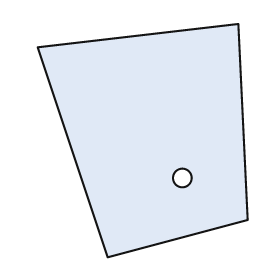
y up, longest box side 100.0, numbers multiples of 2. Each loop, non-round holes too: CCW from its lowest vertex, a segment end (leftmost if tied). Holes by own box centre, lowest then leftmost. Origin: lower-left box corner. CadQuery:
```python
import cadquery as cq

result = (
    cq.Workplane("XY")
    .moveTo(30.0, 0.0)
    .lineTo(90.0, 16.0)
    .lineTo(86.0, 100.0)
    .lineTo(0.0, 90.0)
    .close()
    .moveTo(62.0, 34.0)
    .circle(4.0)
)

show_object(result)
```